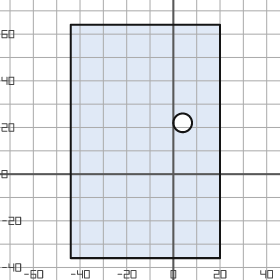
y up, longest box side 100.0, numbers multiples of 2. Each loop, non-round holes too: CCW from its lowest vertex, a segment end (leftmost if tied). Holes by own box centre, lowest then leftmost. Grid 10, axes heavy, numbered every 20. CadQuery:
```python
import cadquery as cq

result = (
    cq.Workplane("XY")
    .moveTo(-44.0, -36.0)
    .lineTo(20.0, -36.0)
    .lineTo(20.0, 64.0)
    .lineTo(-44.0, 64.0)
    .close()
    .moveTo(4.0, 22.0)
    .circle(4.0)
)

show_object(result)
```